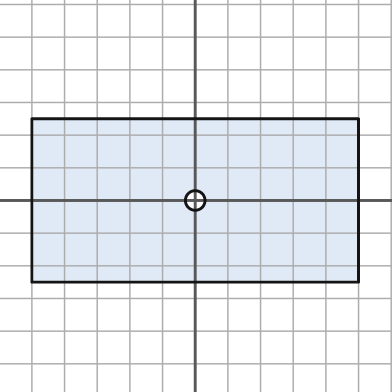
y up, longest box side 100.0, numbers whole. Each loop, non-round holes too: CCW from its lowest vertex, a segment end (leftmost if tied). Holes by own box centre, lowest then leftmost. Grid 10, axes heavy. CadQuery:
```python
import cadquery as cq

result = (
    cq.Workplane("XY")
    .moveTo(-50.0, -25.0)
    .lineTo(50.0, -25.0)
    .lineTo(50.0, 25.0)
    .lineTo(-50.0, 25.0)
    .close()
    .moveTo(0.0, 0.0)
    .circle(3.0)
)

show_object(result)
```